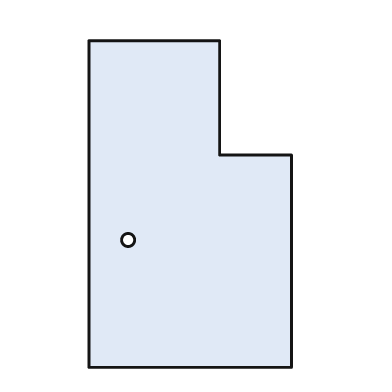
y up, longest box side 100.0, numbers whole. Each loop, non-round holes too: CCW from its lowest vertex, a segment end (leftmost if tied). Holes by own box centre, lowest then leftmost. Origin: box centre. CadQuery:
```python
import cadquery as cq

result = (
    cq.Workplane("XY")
    .moveTo(-31.0, -50.0)
    .lineTo(31.0, -50.0)
    .lineTo(31.0, 15.0)
    .lineTo(9.0, 15.0)
    .lineTo(9.0, 50.0)
    .lineTo(-31.0, 50.0)
    .close()
    .moveTo(-19.0, -11.0)
    .circle(2.0)
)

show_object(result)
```